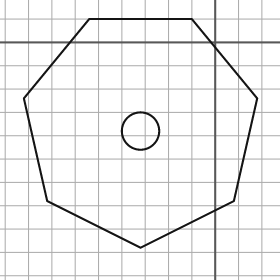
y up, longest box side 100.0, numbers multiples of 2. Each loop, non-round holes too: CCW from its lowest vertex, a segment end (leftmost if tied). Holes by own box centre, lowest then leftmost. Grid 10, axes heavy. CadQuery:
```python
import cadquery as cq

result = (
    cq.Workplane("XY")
    .moveTo(-32.0, -88.0)
    .lineTo(8.0, -68.0)
    .lineTo(18.0, -24.0)
    .lineTo(-10.0, 10.0)
    .lineTo(-54.0, 10.0)
    .lineTo(-82.0, -24.0)
    .lineTo(-72.0, -68.0)
    .close()
    .moveTo(-32.0, -38.0)
    .circle(8.0)
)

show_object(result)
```